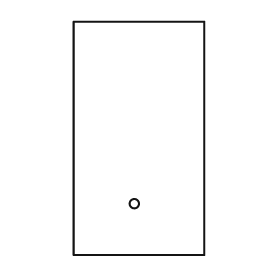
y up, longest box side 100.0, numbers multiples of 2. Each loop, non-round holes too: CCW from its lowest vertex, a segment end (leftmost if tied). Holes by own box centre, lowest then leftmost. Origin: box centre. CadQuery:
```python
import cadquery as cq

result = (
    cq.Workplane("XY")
    .moveTo(-28.0, -50.0)
    .lineTo(28.0, -50.0)
    .lineTo(28.0, 50.0)
    .lineTo(-28.0, 50.0)
    .close()
    .moveTo(-2.0, -28.0)
    .circle(2.0)
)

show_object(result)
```